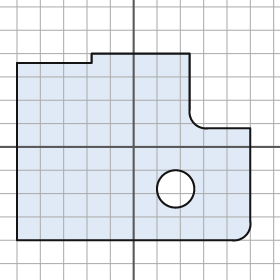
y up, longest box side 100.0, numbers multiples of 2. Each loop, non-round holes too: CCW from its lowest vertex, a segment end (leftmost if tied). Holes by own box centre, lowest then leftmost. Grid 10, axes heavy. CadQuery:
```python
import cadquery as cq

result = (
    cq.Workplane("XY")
    .moveTo(-50.0, -40.0)
    .lineTo(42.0, -40.0)
    .threePointArc((48.0, -38.0), (50.0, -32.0))
    .lineTo(50.0, 8.0)
    .lineTo(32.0, 8.0)
    .threePointArc((26.0, 10.0), (24.0, 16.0))
    .lineTo(24.0, 40.0)
    .lineTo(-18.0, 40.0)
    .lineTo(-18.0, 36.0)
    .lineTo(-50.0, 36.0)
    .close()
    .moveTo(18.0, -18.0)
    .circle(8.0)
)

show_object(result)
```